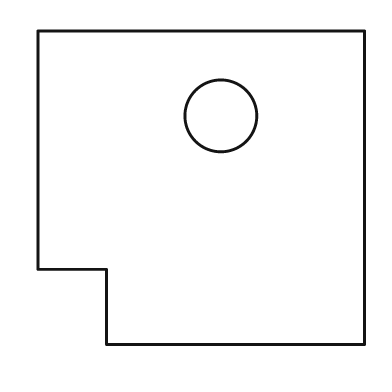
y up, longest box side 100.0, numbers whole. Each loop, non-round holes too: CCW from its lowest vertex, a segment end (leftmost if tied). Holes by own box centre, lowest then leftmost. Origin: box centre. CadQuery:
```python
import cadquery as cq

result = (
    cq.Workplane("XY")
    .moveTo(-29.0, -48.0)
    .lineTo(50.0, -48.0)
    .lineTo(50.0, 48.0)
    .lineTo(-50.0, 48.0)
    .lineTo(-50.0, -25.0)
    .lineTo(-29.0, -25.0)
    .close()
    .moveTo(6.0, 22.0)
    .circle(11.0)
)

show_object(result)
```